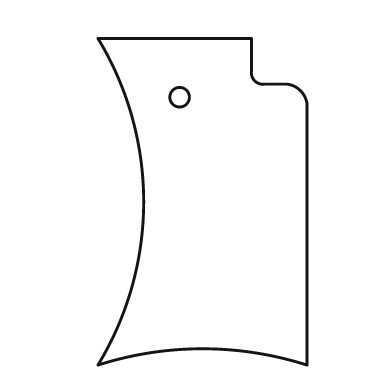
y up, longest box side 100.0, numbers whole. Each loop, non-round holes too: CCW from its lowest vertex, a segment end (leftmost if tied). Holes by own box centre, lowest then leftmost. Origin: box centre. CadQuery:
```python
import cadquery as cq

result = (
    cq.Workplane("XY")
    .moveTo(-32.0, -50.0)
    .threePointArc((0.0, -45.0), (32.0, -50.0))
    .lineTo(32.0, 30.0)
    .threePointArc((30.0, 34.0), (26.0, 36.0))
    .lineTo(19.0, 36.0)
    .threePointArc((16.0, 37.0), (15.0, 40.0))
    .lineTo(15.0, 50.0)
    .lineTo(-32.0, 50.0)
    .threePointArc((-18.0, 0.0), (-32.0, -50.0))
    .close()
    .moveTo(-7.0, 32.0)
    .circle(3.0)
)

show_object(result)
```